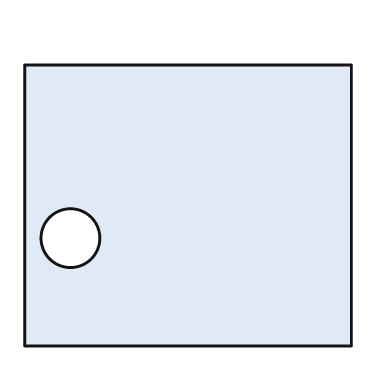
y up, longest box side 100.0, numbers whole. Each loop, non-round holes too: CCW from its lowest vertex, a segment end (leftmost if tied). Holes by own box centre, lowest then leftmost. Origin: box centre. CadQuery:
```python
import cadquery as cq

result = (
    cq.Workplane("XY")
    .moveTo(-50.0, -43.0)
    .lineTo(50.0, -43.0)
    .lineTo(50.0, 43.0)
    .lineTo(-50.0, 43.0)
    .close()
    .moveTo(-36.0, -10.0)
    .circle(9.0)
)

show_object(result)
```